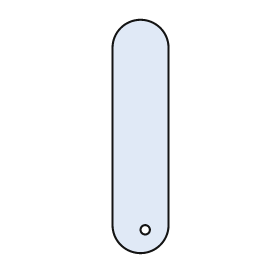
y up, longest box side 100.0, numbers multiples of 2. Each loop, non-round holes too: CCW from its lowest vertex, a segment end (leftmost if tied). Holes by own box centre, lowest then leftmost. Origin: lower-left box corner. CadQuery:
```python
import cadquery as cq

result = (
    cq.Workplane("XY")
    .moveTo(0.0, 12.0)
    .threePointArc((12.0, 0.0), (24.0, 12.0))
    .lineTo(24.0, 88.0)
    .threePointArc((12.0, 100.0), (0.0, 88.0))
    .close()
    .moveTo(14.0, 10.0)
    .circle(2.0)
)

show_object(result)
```